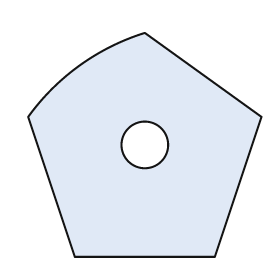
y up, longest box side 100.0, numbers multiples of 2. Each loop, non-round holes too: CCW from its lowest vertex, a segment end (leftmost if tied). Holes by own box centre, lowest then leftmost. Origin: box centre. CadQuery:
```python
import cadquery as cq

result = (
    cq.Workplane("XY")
    .moveTo(-30.0, -48.0)
    .lineTo(30.0, -48.0)
    .lineTo(50.0, 12.0)
    .lineTo(0.0, 48.0)
    .threePointArc((-28.0, 34.0), (-50.0, 12.0))
    .close()
    .moveTo(0.0, 0.0)
    .circle(10.0)
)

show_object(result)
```